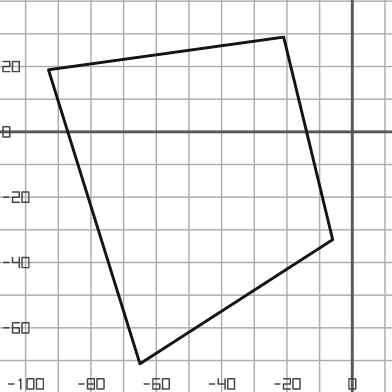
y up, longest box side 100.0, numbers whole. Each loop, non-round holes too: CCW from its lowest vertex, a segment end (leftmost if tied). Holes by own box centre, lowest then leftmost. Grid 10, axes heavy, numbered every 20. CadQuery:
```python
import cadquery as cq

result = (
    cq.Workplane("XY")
    .moveTo(-65.0, -71.0)
    .lineTo(-6.0, -33.0)
    .lineTo(-21.0, 29.0)
    .lineTo(-93.0, 19.0)
    .close()
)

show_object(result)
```